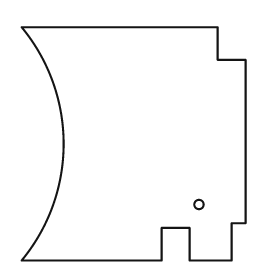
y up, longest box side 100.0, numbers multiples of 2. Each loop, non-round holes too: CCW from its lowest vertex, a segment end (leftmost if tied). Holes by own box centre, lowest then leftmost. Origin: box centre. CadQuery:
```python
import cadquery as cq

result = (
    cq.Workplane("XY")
    .moveTo(-48.0, -50.0)
    .lineTo(12.0, -50.0)
    .lineTo(12.0, -36.0)
    .lineTo(24.0, -36.0)
    .lineTo(24.0, -50.0)
    .lineTo(42.0, -50.0)
    .lineTo(42.0, -34.0)
    .lineTo(48.0, -34.0)
    .lineTo(48.0, 36.0)
    .lineTo(36.0, 36.0)
    .lineTo(36.0, 50.0)
    .lineTo(-48.0, 50.0)
    .threePointArc((-30.0, 0.0), (-48.0, -50.0))
    .close()
    .moveTo(28.0, -26.0)
    .circle(2.0)
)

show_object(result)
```